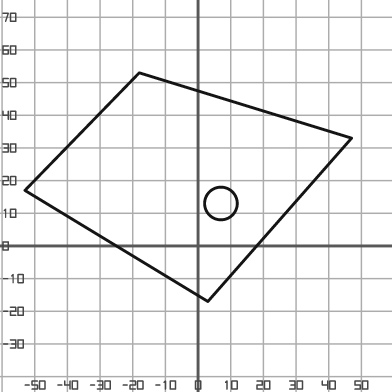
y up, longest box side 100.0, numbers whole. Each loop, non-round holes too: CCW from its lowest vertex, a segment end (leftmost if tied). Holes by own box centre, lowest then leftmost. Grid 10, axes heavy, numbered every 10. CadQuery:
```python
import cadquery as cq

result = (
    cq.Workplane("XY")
    .moveTo(3.0, -17.0)
    .lineTo(47.0, 33.0)
    .lineTo(-18.0, 53.0)
    .lineTo(-53.0, 17.0)
    .close()
    .moveTo(7.0, 13.0)
    .circle(5.0)
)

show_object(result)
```